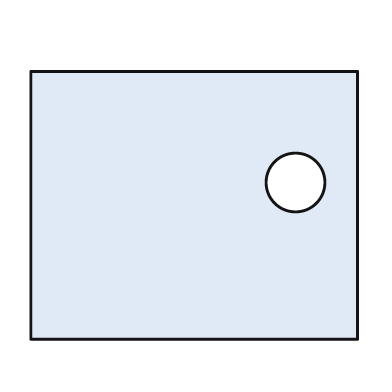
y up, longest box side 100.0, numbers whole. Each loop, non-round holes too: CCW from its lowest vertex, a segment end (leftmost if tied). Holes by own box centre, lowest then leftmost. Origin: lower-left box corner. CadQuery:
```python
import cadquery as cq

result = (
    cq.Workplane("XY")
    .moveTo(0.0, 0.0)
    .lineTo(100.0, 0.0)
    .lineTo(100.0, 82.0)
    .lineTo(0.0, 82.0)
    .close()
    .moveTo(81.0, 48.0)
    .circle(9.0)
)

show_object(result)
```